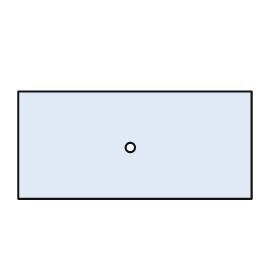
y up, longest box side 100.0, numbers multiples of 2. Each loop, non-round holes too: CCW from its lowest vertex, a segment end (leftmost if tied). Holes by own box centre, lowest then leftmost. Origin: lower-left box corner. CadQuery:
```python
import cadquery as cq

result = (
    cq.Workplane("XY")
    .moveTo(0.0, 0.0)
    .lineTo(100.0, 0.0)
    .lineTo(100.0, 46.0)
    .lineTo(0.0, 46.0)
    .close()
    .moveTo(48.0, 22.0)
    .circle(2.0)
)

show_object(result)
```